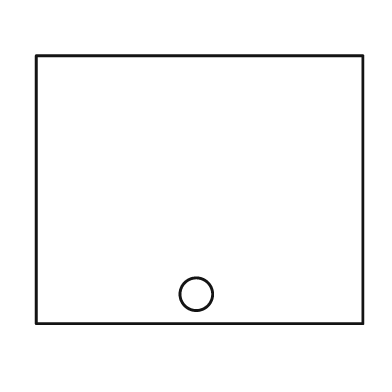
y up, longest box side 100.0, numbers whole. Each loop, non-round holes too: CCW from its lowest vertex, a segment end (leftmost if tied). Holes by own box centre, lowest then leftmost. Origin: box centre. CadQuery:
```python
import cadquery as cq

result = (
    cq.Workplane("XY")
    .moveTo(-50.0, -41.0)
    .lineTo(50.0, -41.0)
    .lineTo(50.0, 41.0)
    .lineTo(-50.0, 41.0)
    .close()
    .moveTo(-1.0, -32.0)
    .circle(5.0)
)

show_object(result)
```